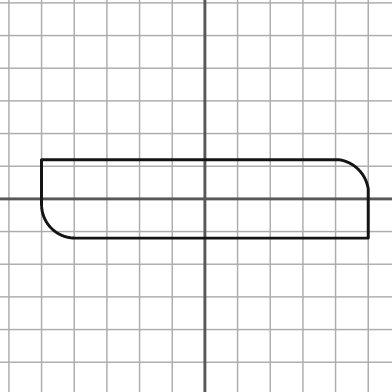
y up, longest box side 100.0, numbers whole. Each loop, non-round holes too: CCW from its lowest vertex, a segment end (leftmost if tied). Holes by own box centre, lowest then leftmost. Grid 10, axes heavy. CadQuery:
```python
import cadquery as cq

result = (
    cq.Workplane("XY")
    .moveTo(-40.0, -12.0)
    .lineTo(50.0, -12.0)
    .lineTo(50.0, 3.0)
    .threePointArc((47.0, 9.0), (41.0, 12.0))
    .lineTo(-50.0, 12.0)
    .lineTo(-50.0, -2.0)
    .threePointArc((-47.0, -9.0), (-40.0, -12.0))
    .close()
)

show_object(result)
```